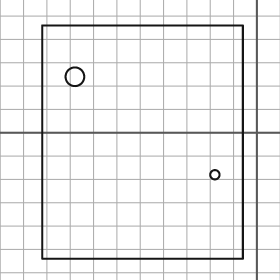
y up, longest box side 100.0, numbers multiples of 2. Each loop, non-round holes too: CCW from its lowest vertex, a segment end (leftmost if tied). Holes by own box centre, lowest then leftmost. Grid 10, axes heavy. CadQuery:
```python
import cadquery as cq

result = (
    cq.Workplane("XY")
    .moveTo(-92.0, -54.0)
    .lineTo(-6.0, -54.0)
    .lineTo(-6.0, 46.0)
    .lineTo(-92.0, 46.0)
    .close()
    .moveTo(-18.0, -18.0)
    .circle(2.0)
    .moveTo(-78.0, 24.0)
    .circle(4.0)
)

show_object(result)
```